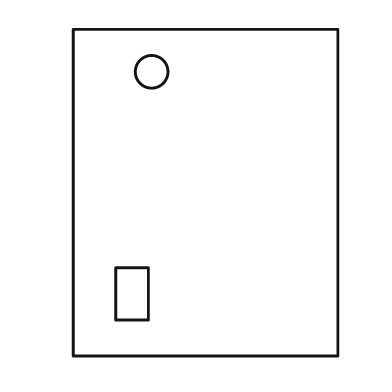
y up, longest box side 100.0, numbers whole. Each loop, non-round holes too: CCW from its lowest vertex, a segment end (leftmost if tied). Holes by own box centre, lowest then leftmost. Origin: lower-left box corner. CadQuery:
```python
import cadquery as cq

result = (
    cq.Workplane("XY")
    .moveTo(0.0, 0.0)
    .lineTo(81.0, 0.0)
    .lineTo(81.0, 100.0)
    .lineTo(0.0, 100.0)
    .close()
    .moveTo(13.0, 11.0)
    .lineTo(23.0, 11.0)
    .lineTo(23.0, 27.0)
    .lineTo(13.0, 27.0)
    .close()
    .moveTo(24.0, 87.0)
    .circle(5.0)
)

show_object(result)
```